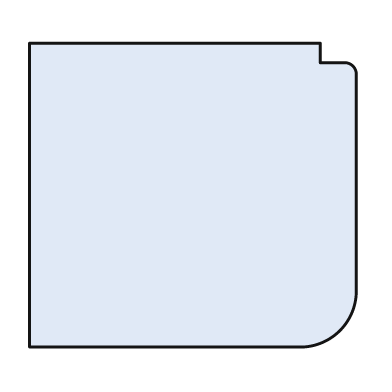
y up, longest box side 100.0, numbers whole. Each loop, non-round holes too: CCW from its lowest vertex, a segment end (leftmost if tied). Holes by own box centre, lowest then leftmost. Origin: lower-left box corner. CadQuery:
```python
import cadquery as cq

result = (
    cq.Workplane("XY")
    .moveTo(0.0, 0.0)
    .lineTo(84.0, 0.0)
    .threePointArc((95.0, 5.0), (100.0, 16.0))
    .lineTo(100.0, 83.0)
    .threePointArc((99.0, 86.0), (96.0, 87.0))
    .lineTo(89.0, 87.0)
    .lineTo(89.0, 93.0)
    .lineTo(0.0, 93.0)
    .close()
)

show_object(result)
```